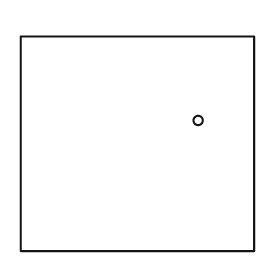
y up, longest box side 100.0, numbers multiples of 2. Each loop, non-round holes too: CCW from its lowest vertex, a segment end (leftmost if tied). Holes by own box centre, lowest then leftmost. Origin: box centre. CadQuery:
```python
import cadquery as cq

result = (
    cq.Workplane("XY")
    .moveTo(-50.0, -46.0)
    .lineTo(50.0, -46.0)
    .lineTo(50.0, 46.0)
    .lineTo(-50.0, 46.0)
    .close()
    .moveTo(26.0, 10.0)
    .circle(2.0)
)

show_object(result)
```